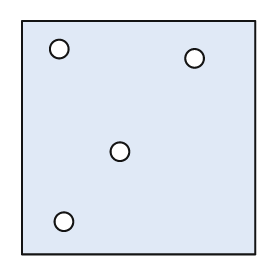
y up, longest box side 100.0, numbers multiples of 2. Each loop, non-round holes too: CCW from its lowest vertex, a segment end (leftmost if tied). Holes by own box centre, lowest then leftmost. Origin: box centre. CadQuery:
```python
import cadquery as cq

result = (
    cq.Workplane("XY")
    .moveTo(-50.0, -50.0)
    .lineTo(50.0, -50.0)
    .lineTo(50.0, 50.0)
    .lineTo(-50.0, 50.0)
    .close()
    .moveTo(-32.0, -36.0)
    .circle(4.0)
    .moveTo(-8.0, -6.0)
    .circle(4.0)
    .moveTo(24.0, 34.0)
    .circle(4.0)
    .moveTo(-34.0, 38.0)
    .circle(4.0)
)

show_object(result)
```